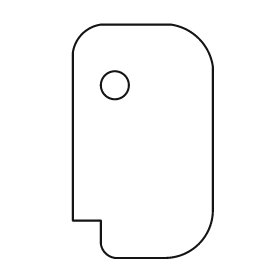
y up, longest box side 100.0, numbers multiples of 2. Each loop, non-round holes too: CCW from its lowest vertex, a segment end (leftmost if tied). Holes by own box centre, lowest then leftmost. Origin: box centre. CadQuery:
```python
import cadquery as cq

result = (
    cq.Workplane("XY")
    .moveTo(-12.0, -50.0)
    .lineTo(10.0, -50.0)
    .threePointArc((24.0, -44.0), (30.0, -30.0))
    .lineTo(30.0, 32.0)
    .threePointArc((24.0, 44.0), (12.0, 50.0))
    .lineTo(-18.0, 50.0)
    .threePointArc((-26.0, 46.0), (-30.0, 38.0))
    .lineTo(-30.0, -34.0)
    .lineTo(-18.0, -34.0)
    .lineTo(-18.0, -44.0)
    .threePointArc((-16.0, -48.0), (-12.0, -50.0))
    .close()
    .moveTo(-12.0, 24.0)
    .circle(6.0)
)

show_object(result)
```